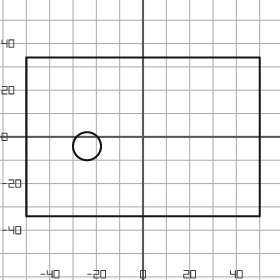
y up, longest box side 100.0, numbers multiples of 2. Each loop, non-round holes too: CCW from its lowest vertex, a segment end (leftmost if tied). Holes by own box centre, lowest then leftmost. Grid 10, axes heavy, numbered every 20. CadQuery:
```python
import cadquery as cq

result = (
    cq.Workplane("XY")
    .moveTo(-50.0, -34.0)
    .lineTo(50.0, -34.0)
    .lineTo(50.0, 34.0)
    .lineTo(-50.0, 34.0)
    .close()
    .moveTo(-24.0, -4.0)
    .circle(6.0)
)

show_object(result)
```